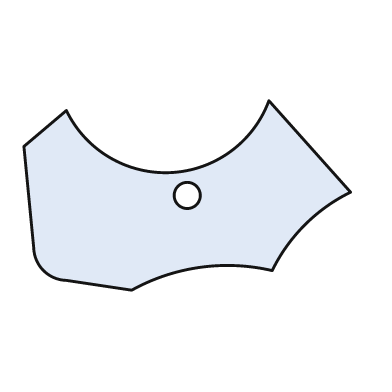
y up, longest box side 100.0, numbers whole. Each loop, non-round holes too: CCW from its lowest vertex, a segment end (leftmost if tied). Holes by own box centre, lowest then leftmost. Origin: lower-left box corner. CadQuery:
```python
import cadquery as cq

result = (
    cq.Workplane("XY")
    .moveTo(33.0, 0.0)
    .threePointArc((54.0, 7.0), (76.0, 6.0))
    .threePointArc((86.0, 20.0), (100.0, 30.0))
    .lineTo(75.0, 58.0)
    .threePointArc((45.0, 36.0), (13.0, 55.0))
    .lineTo(0.0, 44.0)
    .lineTo(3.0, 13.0)
    .threePointArc((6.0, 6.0), (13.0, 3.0))
    .close()
    .moveTo(50.0, 29.0)
    .circle(4.0)
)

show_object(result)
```